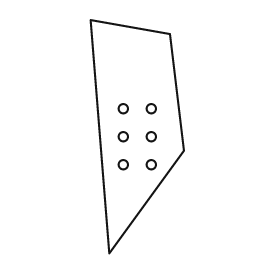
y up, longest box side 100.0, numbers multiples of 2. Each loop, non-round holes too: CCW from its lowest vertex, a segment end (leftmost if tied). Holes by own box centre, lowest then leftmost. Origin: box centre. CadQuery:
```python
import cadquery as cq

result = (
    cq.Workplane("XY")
    .moveTo(-12.0, -50.0)
    .lineTo(20.0, -6.0)
    .lineTo(14.0, 44.0)
    .lineTo(-20.0, 50.0)
    .close()
    .moveTo(-6.0, -12.0)
    .circle(2.0)
    .moveTo(6.0, -12.0)
    .circle(2.0)
    .moveTo(-6.0, 0.0)
    .circle(2.0)
    .moveTo(6.0, 0.0)
    .circle(2.0)
    .moveTo(-6.0, 12.0)
    .circle(2.0)
    .moveTo(6.0, 12.0)
    .circle(2.0)
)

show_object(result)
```